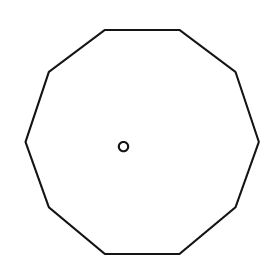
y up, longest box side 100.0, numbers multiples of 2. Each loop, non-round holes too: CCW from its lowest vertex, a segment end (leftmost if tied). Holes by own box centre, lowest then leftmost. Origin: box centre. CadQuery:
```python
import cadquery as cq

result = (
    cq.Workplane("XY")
    .moveTo(-16.0, -48.0)
    .lineTo(16.0, -48.0)
    .lineTo(40.0, -28.0)
    .lineTo(50.0, 0.0)
    .lineTo(40.0, 30.0)
    .lineTo(16.0, 48.0)
    .lineTo(-16.0, 48.0)
    .lineTo(-40.0, 30.0)
    .lineTo(-50.0, 0.0)
    .lineTo(-40.0, -28.0)
    .close()
    .moveTo(-8.0, -2.0)
    .circle(2.0)
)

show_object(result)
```